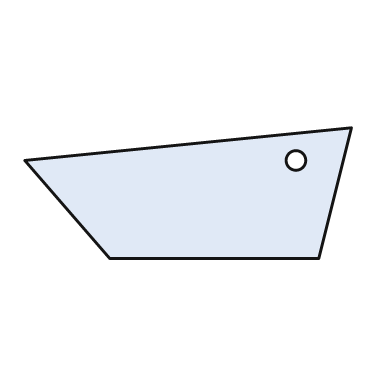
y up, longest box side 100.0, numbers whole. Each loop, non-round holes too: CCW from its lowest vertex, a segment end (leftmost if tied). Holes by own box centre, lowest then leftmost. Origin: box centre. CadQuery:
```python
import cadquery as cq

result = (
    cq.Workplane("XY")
    .moveTo(-24.0, -20.0)
    .lineTo(40.0, -20.0)
    .lineTo(50.0, 20.0)
    .lineTo(-50.0, 10.0)
    .close()
    .moveTo(33.0, 10.0)
    .circle(3.0)
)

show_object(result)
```